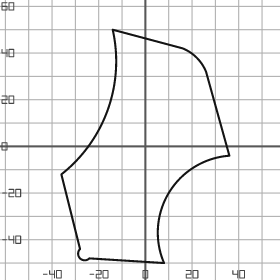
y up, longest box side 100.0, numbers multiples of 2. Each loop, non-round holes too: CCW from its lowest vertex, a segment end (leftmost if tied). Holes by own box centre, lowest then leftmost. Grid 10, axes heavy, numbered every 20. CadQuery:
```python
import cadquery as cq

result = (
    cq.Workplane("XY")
    .moveTo(8.0, -50.0)
    .threePointArc((10.0, -20.0), (36.0, -4.0))
    .lineTo(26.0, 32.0)
    .threePointArc((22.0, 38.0), (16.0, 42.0))
    .lineTo(-14.0, 50.0)
    .threePointArc((-16.0, 16.0), (-36.0, -12.0))
    .lineTo(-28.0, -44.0)
    .threePointArc((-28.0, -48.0), (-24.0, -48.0))
    .close()
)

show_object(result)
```